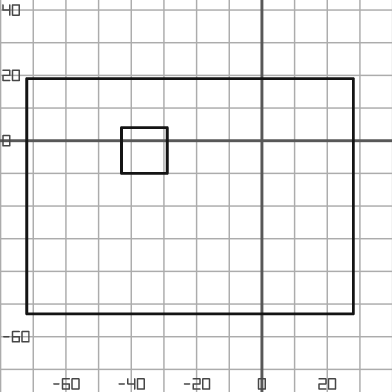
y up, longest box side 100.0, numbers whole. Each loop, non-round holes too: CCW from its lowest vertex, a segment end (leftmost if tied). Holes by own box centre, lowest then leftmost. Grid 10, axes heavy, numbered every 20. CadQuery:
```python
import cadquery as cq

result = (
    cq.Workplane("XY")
    .moveTo(-72.0, -53.0)
    .lineTo(28.0, -53.0)
    .lineTo(28.0, 19.0)
    .lineTo(-72.0, 19.0)
    .close()
    .moveTo(-43.0, -10.0)
    .lineTo(-29.0, -10.0)
    .lineTo(-29.0, 4.0)
    .lineTo(-43.0, 4.0)
    .close()
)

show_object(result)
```